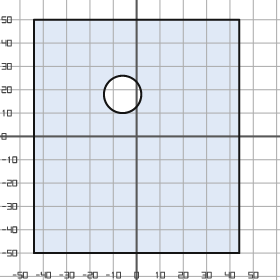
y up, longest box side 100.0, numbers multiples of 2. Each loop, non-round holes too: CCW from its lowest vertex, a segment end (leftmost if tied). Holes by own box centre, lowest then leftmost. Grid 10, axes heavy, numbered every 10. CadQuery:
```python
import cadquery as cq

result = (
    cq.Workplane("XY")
    .moveTo(-44.0, -50.0)
    .lineTo(44.0, -50.0)
    .lineTo(44.0, 50.0)
    .lineTo(-44.0, 50.0)
    .close()
    .moveTo(-6.0, 18.0)
    .circle(8.0)
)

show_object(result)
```